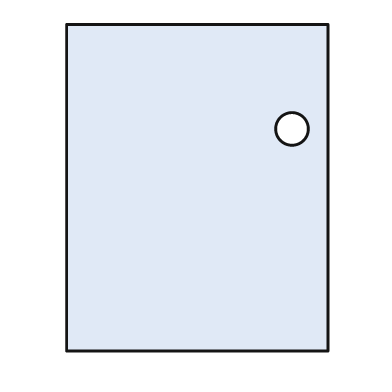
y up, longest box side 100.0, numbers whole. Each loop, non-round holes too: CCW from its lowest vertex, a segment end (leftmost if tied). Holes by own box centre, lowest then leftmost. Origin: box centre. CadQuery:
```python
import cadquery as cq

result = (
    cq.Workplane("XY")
    .moveTo(-40.0, -50.0)
    .lineTo(40.0, -50.0)
    .lineTo(40.0, 50.0)
    .lineTo(-40.0, 50.0)
    .close()
    .moveTo(29.0, 18.0)
    .circle(5.0)
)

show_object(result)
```